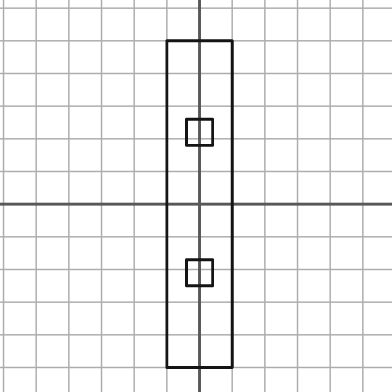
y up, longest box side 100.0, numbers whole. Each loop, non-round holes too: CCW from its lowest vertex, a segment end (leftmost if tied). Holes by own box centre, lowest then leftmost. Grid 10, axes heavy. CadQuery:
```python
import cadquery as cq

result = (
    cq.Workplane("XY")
    .moveTo(-10.0, -50.0)
    .lineTo(10.0, -50.0)
    .lineTo(10.0, 50.0)
    .lineTo(-10.0, 50.0)
    .close()
    .moveTo(-4.0, -25.0)
    .lineTo(4.0, -25.0)
    .lineTo(4.0, -17.0)
    .lineTo(-4.0, -17.0)
    .close()
    .moveTo(-4.0, 18.0)
    .lineTo(4.0, 18.0)
    .lineTo(4.0, 26.0)
    .lineTo(-4.0, 26.0)
    .close()
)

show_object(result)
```